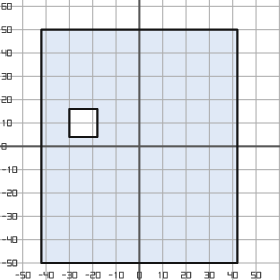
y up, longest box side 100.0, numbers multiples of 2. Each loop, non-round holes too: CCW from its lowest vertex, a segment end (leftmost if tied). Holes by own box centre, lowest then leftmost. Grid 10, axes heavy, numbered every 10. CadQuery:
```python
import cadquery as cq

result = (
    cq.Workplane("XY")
    .moveTo(-42.0, -50.0)
    .lineTo(42.0, -50.0)
    .lineTo(42.0, 50.0)
    .lineTo(-42.0, 50.0)
    .close()
    .moveTo(-30.0, 4.0)
    .lineTo(-18.0, 4.0)
    .lineTo(-18.0, 16.0)
    .lineTo(-30.0, 16.0)
    .close()
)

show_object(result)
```